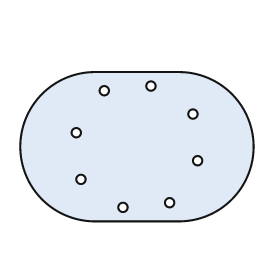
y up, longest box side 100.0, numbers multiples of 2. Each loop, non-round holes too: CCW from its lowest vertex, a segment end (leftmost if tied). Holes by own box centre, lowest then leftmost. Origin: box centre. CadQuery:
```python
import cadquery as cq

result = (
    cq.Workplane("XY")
    .moveTo(-18.0, -32.0)
    .lineTo(18.0, -32.0)
    .threePointArc((50.0, 0.0), (18.0, 32.0))
    .lineTo(-18.0, 32.0)
    .threePointArc((-50.0, 0.0), (-18.0, -32.0))
    .close()
    .moveTo(-6.0, -26.0)
    .circle(2.0)
    .moveTo(14.0, -24.0)
    .circle(2.0)
    .moveTo(-24.0, -14.0)
    .circle(2.0)
    .moveTo(26.0, -6.0)
    .circle(2.0)
    .moveTo(-26.0, 6.0)
    .circle(2.0)
    .moveTo(24.0, 14.0)
    .circle(2.0)
    .moveTo(-14.0, 24.0)
    .circle(2.0)
    .moveTo(6.0, 26.0)
    .circle(2.0)
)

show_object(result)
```